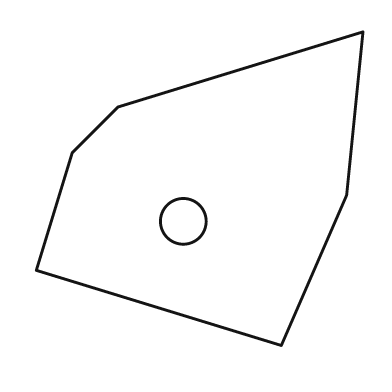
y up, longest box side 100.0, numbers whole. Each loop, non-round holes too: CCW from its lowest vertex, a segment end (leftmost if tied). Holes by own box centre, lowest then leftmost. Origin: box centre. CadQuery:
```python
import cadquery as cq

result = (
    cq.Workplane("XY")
    .moveTo(25.0, -48.0)
    .lineTo(45.0, -2.0)
    .lineTo(50.0, 48.0)
    .lineTo(-25.0, 25.0)
    .lineTo(-39.0, 11.0)
    .lineTo(-50.0, -25.0)
    .close()
    .moveTo(-5.0, -10.0)
    .circle(7.0)
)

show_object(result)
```